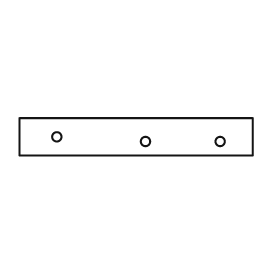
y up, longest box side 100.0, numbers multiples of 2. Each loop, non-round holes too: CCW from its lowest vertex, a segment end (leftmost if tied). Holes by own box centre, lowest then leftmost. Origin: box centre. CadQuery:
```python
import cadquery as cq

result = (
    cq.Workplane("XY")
    .moveTo(-50.0, -8.0)
    .lineTo(50.0, -8.0)
    .lineTo(50.0, 8.0)
    .lineTo(-50.0, 8.0)
    .close()
    .moveTo(4.0, -2.0)
    .circle(2.0)
    .moveTo(36.0, -2.0)
    .circle(2.0)
    .moveTo(-34.0, 0.0)
    .circle(2.0)
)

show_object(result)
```